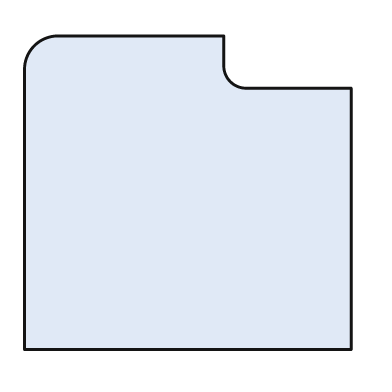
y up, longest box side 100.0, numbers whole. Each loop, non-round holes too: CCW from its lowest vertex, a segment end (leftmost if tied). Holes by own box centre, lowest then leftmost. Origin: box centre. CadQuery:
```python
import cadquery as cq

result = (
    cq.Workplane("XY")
    .moveTo(-50.0, -48.0)
    .lineTo(50.0, -48.0)
    .lineTo(50.0, 32.0)
    .lineTo(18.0, 32.0)
    .threePointArc((13.0, 34.0), (11.0, 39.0))
    .lineTo(11.0, 48.0)
    .lineTo(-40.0, 48.0)
    .threePointArc((-47.0, 45.0), (-50.0, 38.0))
    .close()
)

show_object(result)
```